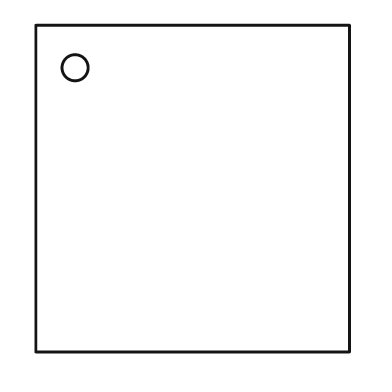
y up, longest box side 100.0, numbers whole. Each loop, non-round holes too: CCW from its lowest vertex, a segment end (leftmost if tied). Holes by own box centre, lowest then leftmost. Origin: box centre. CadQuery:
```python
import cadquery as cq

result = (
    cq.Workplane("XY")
    .moveTo(-48.0, -50.0)
    .lineTo(48.0, -50.0)
    .lineTo(48.0, 50.0)
    .lineTo(-48.0, 50.0)
    .close()
    .moveTo(-36.0, 37.0)
    .circle(4.0)
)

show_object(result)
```